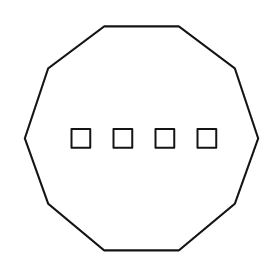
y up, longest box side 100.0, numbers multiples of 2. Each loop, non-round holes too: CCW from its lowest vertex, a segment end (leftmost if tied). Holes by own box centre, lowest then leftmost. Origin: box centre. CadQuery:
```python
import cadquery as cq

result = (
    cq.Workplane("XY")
    .moveTo(-16.0, -48.0)
    .lineTo(16.0, -48.0)
    .lineTo(40.0, -28.0)
    .lineTo(50.0, 0.0)
    .lineTo(40.0, 30.0)
    .lineTo(16.0, 48.0)
    .lineTo(-16.0, 48.0)
    .lineTo(-40.0, 30.0)
    .lineTo(-50.0, 0.0)
    .lineTo(-40.0, -28.0)
    .close()
    .moveTo(-30.0, -4.0)
    .lineTo(-22.0, -4.0)
    .lineTo(-22.0, 4.0)
    .lineTo(-30.0, 4.0)
    .close()
    .moveTo(-12.0, -4.0)
    .lineTo(-4.0, -4.0)
    .lineTo(-4.0, 4.0)
    .lineTo(-12.0, 4.0)
    .close()
    .moveTo(6.0, -4.0)
    .lineTo(14.0, -4.0)
    .lineTo(14.0, 4.0)
    .lineTo(6.0, 4.0)
    .close()
    .moveTo(24.0, -4.0)
    .lineTo(32.0, -4.0)
    .lineTo(32.0, 4.0)
    .lineTo(24.0, 4.0)
    .close()
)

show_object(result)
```